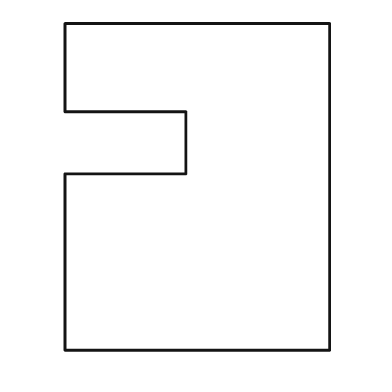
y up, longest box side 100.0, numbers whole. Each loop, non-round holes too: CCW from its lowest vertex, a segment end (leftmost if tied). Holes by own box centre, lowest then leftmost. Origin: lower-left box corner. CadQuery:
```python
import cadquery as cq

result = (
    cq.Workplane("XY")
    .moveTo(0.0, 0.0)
    .lineTo(81.0, 0.0)
    .lineTo(81.0, 100.0)
    .lineTo(0.0, 100.0)
    .lineTo(0.0, 73.0)
    .lineTo(37.0, 73.0)
    .lineTo(37.0, 54.0)
    .lineTo(0.0, 54.0)
    .close()
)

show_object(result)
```